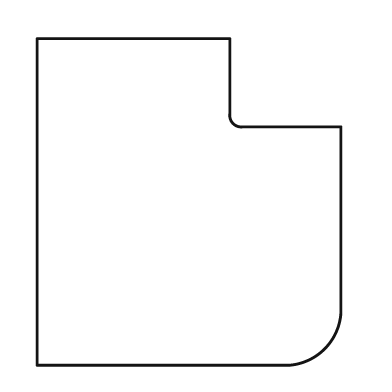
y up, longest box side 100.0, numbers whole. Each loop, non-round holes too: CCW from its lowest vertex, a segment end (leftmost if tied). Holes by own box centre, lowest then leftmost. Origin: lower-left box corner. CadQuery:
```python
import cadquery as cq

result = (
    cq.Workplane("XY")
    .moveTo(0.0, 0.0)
    .lineTo(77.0, 0.0)
    .threePointArc((88.0, 5.0), (93.0, 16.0))
    .lineTo(93.0, 73.0)
    .lineTo(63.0, 73.0)
    .threePointArc((60.0, 74.0), (59.0, 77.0))
    .lineTo(59.0, 100.0)
    .lineTo(0.0, 100.0)
    .close()
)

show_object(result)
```